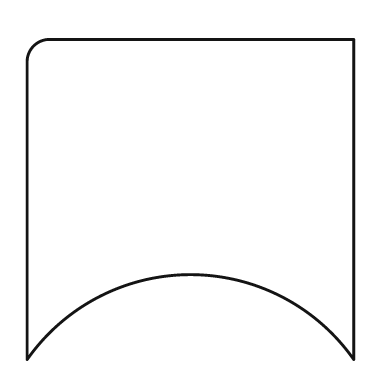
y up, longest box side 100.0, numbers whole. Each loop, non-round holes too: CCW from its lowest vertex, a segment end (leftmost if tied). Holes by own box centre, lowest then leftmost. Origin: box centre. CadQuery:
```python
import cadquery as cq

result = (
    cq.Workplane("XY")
    .moveTo(-50.0, -49.0)
    .threePointArc((0.0, -23.0), (50.0, -49.0))
    .lineTo(50.0, 49.0)
    .lineTo(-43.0, 49.0)
    .threePointArc((-48.0, 47.0), (-50.0, 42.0))
    .close()
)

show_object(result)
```